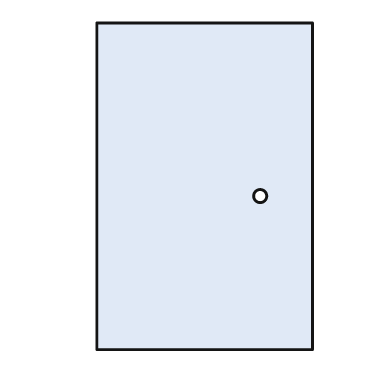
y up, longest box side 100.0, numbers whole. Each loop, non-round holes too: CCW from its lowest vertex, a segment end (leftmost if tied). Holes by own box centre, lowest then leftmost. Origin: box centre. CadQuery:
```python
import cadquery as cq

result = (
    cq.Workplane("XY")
    .moveTo(-33.0, -50.0)
    .lineTo(33.0, -50.0)
    .lineTo(33.0, 50.0)
    .lineTo(-33.0, 50.0)
    .close()
    .moveTo(17.0, -3.0)
    .circle(2.0)
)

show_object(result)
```